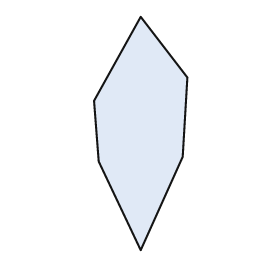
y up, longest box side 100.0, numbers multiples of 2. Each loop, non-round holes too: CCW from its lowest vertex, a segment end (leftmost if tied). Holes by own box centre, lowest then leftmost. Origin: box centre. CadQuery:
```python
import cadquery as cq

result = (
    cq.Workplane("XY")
    .moveTo(0.0, -50.0)
    .lineTo(18.0, -10.0)
    .lineTo(20.0, 24.0)
    .lineTo(0.0, 50.0)
    .lineTo(-20.0, 14.0)
    .lineTo(-18.0, -12.0)
    .close()
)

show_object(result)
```